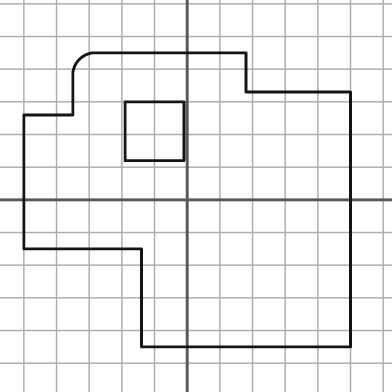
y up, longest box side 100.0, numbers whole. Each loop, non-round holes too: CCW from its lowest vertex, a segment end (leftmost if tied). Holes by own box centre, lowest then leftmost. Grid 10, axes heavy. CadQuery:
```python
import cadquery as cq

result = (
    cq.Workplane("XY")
    .moveTo(-14.0, -45.0)
    .lineTo(50.0, -45.0)
    .lineTo(50.0, 33.0)
    .lineTo(18.0, 33.0)
    .lineTo(18.0, 45.0)
    .lineTo(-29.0, 45.0)
    .threePointArc((-33.0, 43.0), (-35.0, 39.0))
    .lineTo(-35.0, 26.0)
    .lineTo(-50.0, 26.0)
    .lineTo(-50.0, -15.0)
    .lineTo(-14.0, -15.0)
    .close()
    .moveTo(-19.0, 12.0)
    .lineTo(-1.0, 12.0)
    .lineTo(-1.0, 30.0)
    .lineTo(-19.0, 30.0)
    .close()
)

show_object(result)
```